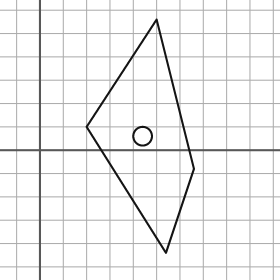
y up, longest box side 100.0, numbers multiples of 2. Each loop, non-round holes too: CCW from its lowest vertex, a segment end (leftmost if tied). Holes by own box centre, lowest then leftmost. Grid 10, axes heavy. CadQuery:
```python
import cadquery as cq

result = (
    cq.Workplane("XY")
    .moveTo(54.0, -44.0)
    .lineTo(66.0, -8.0)
    .lineTo(50.0, 56.0)
    .lineTo(20.0, 10.0)
    .close()
    .moveTo(44.0, 6.0)
    .circle(4.0)
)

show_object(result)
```